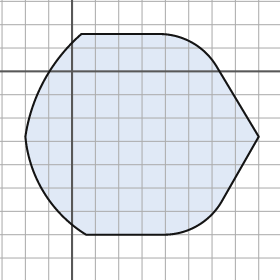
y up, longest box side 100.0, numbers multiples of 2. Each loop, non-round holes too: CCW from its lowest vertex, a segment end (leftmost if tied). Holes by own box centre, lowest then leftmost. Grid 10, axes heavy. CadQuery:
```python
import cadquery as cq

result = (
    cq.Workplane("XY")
    .moveTo(6.0, -70.0)
    .lineTo(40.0, -70.0)
    .threePointArc((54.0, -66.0), (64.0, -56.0))
    .lineTo(80.0, -28.0)
    .lineTo(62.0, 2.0)
    .threePointArc((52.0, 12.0), (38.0, 16.0))
    .lineTo(4.0, 16.0)
    .threePointArc((-12.0, -4.0), (-20.0, -28.0))
    .threePointArc((-12.0, -52.0), (6.0, -70.0))
    .close()
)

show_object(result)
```